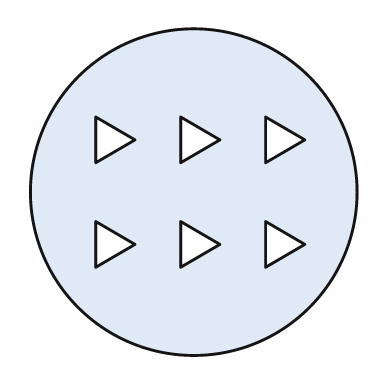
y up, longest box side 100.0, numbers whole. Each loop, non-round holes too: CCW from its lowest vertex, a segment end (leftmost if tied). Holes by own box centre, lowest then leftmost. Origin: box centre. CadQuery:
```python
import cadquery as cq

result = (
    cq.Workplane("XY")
    .moveTo(0.0, 0.0)
    .circle(50.0)
    .moveTo(-30.0, -23.0)
    .lineTo(-18.0, -16.0)
    .lineTo(-30.0, -9.0)
    .close()
    .moveTo(-4.0, -23.0)
    .lineTo(8.0, -16.0)
    .lineTo(-4.0, -9.0)
    .close()
    .moveTo(22.0, -23.0)
    .lineTo(34.0, -16.0)
    .lineTo(22.0, -9.0)
    .close()
    .moveTo(-30.0, 9.0)
    .lineTo(-18.0, 16.0)
    .lineTo(-30.0, 23.0)
    .close()
    .moveTo(-4.0, 9.0)
    .lineTo(8.0, 16.0)
    .lineTo(-4.0, 23.0)
    .close()
    .moveTo(22.0, 9.0)
    .lineTo(34.0, 16.0)
    .lineTo(22.0, 23.0)
    .close()
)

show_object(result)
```